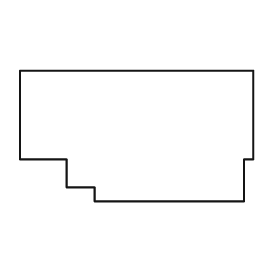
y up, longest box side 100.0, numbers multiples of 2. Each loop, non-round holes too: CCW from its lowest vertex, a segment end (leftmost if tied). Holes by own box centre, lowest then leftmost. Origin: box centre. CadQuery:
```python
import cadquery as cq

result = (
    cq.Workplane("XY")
    .moveTo(-18.0, -28.0)
    .lineTo(46.0, -28.0)
    .lineTo(46.0, -10.0)
    .lineTo(50.0, -10.0)
    .lineTo(50.0, 28.0)
    .lineTo(-50.0, 28.0)
    .lineTo(-50.0, -10.0)
    .lineTo(-30.0, -10.0)
    .lineTo(-30.0, -22.0)
    .lineTo(-18.0, -22.0)
    .close()
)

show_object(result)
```